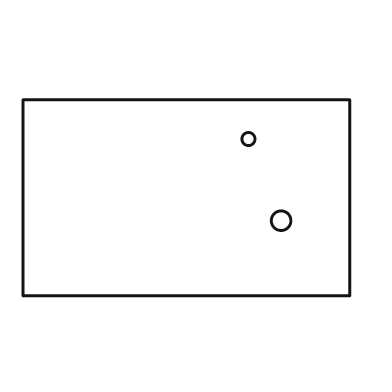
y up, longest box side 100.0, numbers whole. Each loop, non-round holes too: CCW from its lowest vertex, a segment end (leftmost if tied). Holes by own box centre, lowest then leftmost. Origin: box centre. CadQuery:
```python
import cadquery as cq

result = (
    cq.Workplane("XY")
    .moveTo(-50.0, -30.0)
    .lineTo(50.0, -30.0)
    .lineTo(50.0, 30.0)
    .lineTo(-50.0, 30.0)
    .close()
    .moveTo(29.0, -7.0)
    .circle(3.0)
    .moveTo(19.0, 18.0)
    .circle(2.0)
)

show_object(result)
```